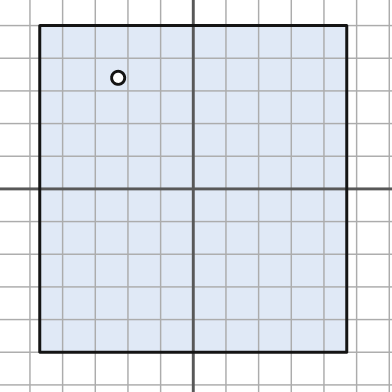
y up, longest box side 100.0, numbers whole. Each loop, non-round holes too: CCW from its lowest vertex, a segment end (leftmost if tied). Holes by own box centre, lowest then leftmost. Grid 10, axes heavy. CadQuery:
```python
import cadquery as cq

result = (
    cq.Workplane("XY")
    .moveTo(-47.0, -50.0)
    .lineTo(47.0, -50.0)
    .lineTo(47.0, 50.0)
    .lineTo(-47.0, 50.0)
    .close()
    .moveTo(-23.0, 34.0)
    .circle(2.0)
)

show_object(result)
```